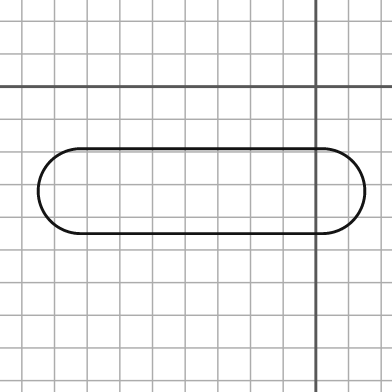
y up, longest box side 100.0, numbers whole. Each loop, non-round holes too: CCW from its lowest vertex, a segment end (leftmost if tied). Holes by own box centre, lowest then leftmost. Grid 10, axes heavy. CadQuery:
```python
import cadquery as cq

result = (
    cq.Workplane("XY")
    .moveTo(-72.0, -45.0)
    .lineTo(2.0, -45.0)
    .threePointArc((15.0, -32.0), (2.0, -19.0))
    .lineTo(-72.0, -19.0)
    .threePointArc((-85.0, -32.0), (-72.0, -45.0))
    .close()
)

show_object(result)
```